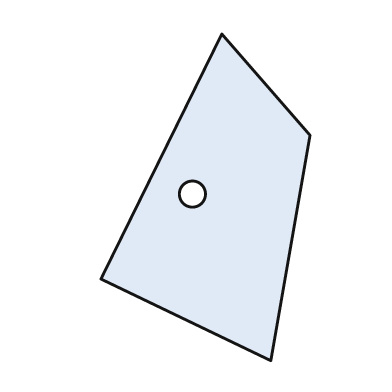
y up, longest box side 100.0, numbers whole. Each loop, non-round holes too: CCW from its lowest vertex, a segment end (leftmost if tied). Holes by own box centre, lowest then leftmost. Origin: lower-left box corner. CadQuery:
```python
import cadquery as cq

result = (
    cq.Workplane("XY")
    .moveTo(52.0, 0.0)
    .lineTo(64.0, 69.0)
    .lineTo(37.0, 100.0)
    .lineTo(0.0, 25.0)
    .close()
    .moveTo(28.0, 51.0)
    .circle(4.0)
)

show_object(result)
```